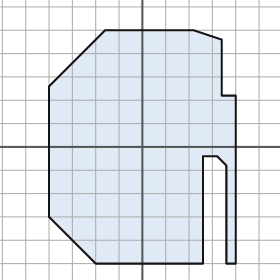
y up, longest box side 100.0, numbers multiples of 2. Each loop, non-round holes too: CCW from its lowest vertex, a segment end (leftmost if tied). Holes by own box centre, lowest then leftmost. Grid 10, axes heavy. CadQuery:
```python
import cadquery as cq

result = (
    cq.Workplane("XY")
    .moveTo(-20.0, -50.0)
    .lineTo(26.0, -50.0)
    .lineTo(26.0, -4.0)
    .lineTo(32.0, -4.0)
    .lineTo(36.0, -8.0)
    .lineTo(36.0, -50.0)
    .lineTo(40.0, -50.0)
    .lineTo(40.0, 22.0)
    .lineTo(34.0, 22.0)
    .lineTo(34.0, 46.0)
    .lineTo(22.0, 50.0)
    .lineTo(-16.0, 50.0)
    .lineTo(-40.0, 26.0)
    .lineTo(-40.0, -30.0)
    .close()
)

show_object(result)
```